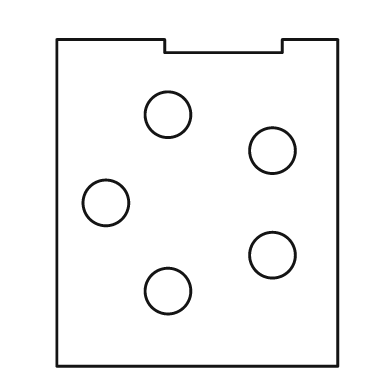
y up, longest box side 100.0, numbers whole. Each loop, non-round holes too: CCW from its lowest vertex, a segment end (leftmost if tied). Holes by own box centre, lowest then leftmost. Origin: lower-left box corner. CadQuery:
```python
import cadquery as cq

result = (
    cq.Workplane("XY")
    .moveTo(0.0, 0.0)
    .lineTo(86.0, 0.0)
    .lineTo(86.0, 100.0)
    .lineTo(69.0, 100.0)
    .lineTo(69.0, 96.0)
    .lineTo(33.0, 96.0)
    .lineTo(33.0, 100.0)
    .lineTo(0.0, 100.0)
    .close()
    .moveTo(34.0, 23.0)
    .circle(7.0)
    .moveTo(66.0, 34.0)
    .circle(7.0)
    .moveTo(15.0, 50.0)
    .circle(7.0)
    .moveTo(66.0, 66.0)
    .circle(7.0)
    .moveTo(34.0, 77.0)
    .circle(7.0)
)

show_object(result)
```